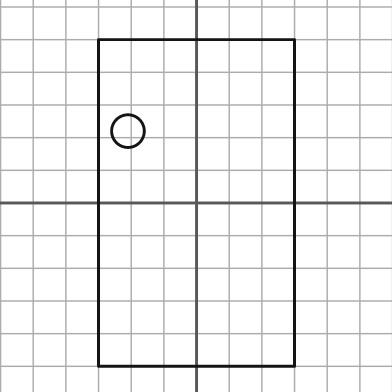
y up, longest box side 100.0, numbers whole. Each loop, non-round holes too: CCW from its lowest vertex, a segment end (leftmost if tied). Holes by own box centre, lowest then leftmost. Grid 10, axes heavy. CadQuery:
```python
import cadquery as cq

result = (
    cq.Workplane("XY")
    .moveTo(-30.0, -50.0)
    .lineTo(30.0, -50.0)
    .lineTo(30.0, 50.0)
    .lineTo(-30.0, 50.0)
    .close()
    .moveTo(-21.0, 22.0)
    .circle(5.0)
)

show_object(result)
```